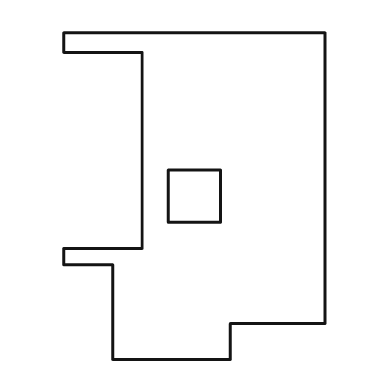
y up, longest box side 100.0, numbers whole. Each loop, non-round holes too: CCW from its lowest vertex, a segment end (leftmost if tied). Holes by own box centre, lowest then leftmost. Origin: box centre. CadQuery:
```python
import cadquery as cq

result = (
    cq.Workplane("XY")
    .moveTo(-25.0, -50.0)
    .lineTo(11.0, -50.0)
    .lineTo(11.0, -39.0)
    .lineTo(40.0, -39.0)
    .lineTo(40.0, 50.0)
    .lineTo(-40.0, 50.0)
    .lineTo(-40.0, 44.0)
    .lineTo(-16.0, 44.0)
    .lineTo(-16.0, -16.0)
    .lineTo(-40.0, -16.0)
    .lineTo(-40.0, -21.0)
    .lineTo(-25.0, -21.0)
    .close()
    .moveTo(-8.0, -8.0)
    .lineTo(8.0, -8.0)
    .lineTo(8.0, 8.0)
    .lineTo(-8.0, 8.0)
    .close()
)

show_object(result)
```